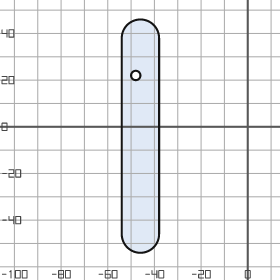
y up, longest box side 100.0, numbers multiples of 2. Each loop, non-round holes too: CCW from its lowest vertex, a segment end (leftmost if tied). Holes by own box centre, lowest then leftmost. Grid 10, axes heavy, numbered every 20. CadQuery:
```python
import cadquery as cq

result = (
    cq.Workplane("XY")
    .moveTo(-54.0, -46.0)
    .threePointArc((-46.0, -54.0), (-38.0, -46.0))
    .lineTo(-38.0, 38.0)
    .threePointArc((-46.0, 46.0), (-54.0, 38.0))
    .close()
    .moveTo(-48.0, 22.0)
    .circle(2.0)
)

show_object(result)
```